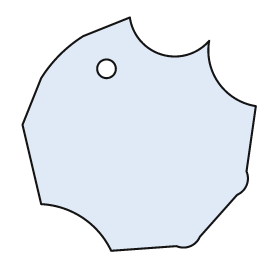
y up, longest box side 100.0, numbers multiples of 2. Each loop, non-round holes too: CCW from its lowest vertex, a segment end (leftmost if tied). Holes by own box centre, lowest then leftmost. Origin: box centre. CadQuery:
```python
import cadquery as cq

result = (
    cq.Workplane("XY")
    .moveTo(-12.0, -50.0)
    .lineTo(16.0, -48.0)
    .threePointArc((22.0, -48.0), (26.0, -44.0))
    .lineTo(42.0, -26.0)
    .threePointArc((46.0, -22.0), (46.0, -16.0))
    .lineTo(50.0, 12.0)
    .threePointArc((34.0, 22.0), (30.0, 40.0))
    .threePointArc((10.0, 34.0), (-4.0, 50.0))
    .lineTo(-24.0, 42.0)
    .threePointArc((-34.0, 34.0), (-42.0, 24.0))
    .lineTo(-50.0, 4.0)
    .lineTo(-42.0, -30.0)
    .threePointArc((-24.0, -36.0), (-12.0, -50.0))
    .close()
    .moveTo(-14.0, 28.0)
    .circle(4.0)
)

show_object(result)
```